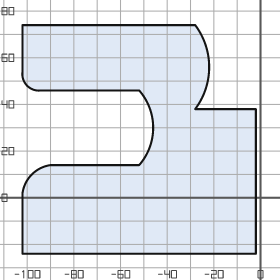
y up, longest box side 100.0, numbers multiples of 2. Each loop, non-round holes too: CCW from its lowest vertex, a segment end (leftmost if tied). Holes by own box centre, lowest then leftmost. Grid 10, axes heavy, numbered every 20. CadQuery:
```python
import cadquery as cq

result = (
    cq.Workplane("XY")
    .moveTo(-102.0, -24.0)
    .lineTo(-2.0, -24.0)
    .lineTo(-2.0, 38.0)
    .lineTo(-28.0, 38.0)
    .threePointArc((-22.0, 56.0), (-28.0, 74.0))
    .lineTo(-102.0, 74.0)
    .lineTo(-102.0, 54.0)
    .threePointArc((-100.0, 48.0), (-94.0, 46.0))
    .lineTo(-52.0, 46.0)
    .threePointArc((-46.0, 30.0), (-52.0, 14.0))
    .lineTo(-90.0, 14.0)
    .threePointArc((-98.0, 10.0), (-102.0, 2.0))
    .close()
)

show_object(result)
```